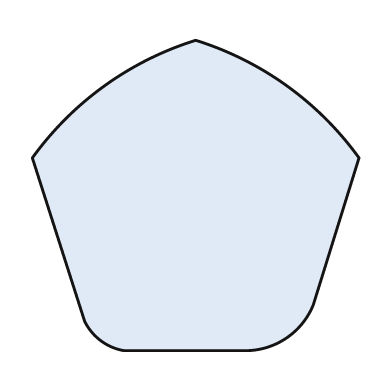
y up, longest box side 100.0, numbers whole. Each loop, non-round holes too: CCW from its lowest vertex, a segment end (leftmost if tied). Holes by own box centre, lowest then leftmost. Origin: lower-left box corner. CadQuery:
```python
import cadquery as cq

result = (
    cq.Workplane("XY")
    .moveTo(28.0, 0.0)
    .lineTo(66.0, 0.0)
    .threePointArc((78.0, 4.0), (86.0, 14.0))
    .lineTo(100.0, 59.0)
    .threePointArc((78.0, 81.0), (50.0, 95.0))
    .threePointArc((22.0, 81.0), (0.0, 59.0))
    .lineTo(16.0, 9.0)
    .threePointArc((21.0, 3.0), (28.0, 0.0))
    .close()
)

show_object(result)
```